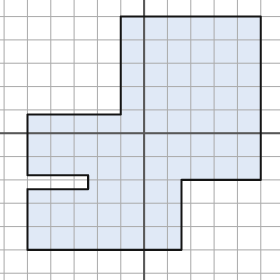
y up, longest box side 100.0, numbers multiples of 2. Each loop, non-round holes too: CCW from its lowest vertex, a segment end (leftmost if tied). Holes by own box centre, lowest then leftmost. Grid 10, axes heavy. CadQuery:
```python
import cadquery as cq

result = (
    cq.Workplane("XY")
    .moveTo(-50.0, -50.0)
    .lineTo(16.0, -50.0)
    .lineTo(16.0, -20.0)
    .lineTo(50.0, -20.0)
    .lineTo(50.0, 50.0)
    .lineTo(-10.0, 50.0)
    .lineTo(-10.0, 8.0)
    .lineTo(-50.0, 8.0)
    .lineTo(-50.0, -18.0)
    .lineTo(-24.0, -18.0)
    .lineTo(-24.0, -24.0)
    .lineTo(-50.0, -24.0)
    .close()
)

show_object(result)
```